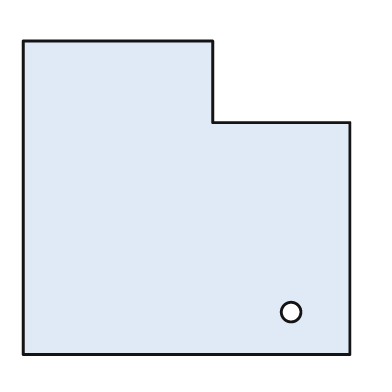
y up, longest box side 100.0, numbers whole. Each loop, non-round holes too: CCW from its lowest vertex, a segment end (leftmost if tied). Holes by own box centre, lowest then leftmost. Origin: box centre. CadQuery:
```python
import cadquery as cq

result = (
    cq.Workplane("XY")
    .moveTo(-50.0, -48.0)
    .lineTo(50.0, -48.0)
    .lineTo(50.0, 23.0)
    .lineTo(8.0, 23.0)
    .lineTo(8.0, 48.0)
    .lineTo(-50.0, 48.0)
    .close()
    .moveTo(32.0, -35.0)
    .circle(3.0)
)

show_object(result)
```